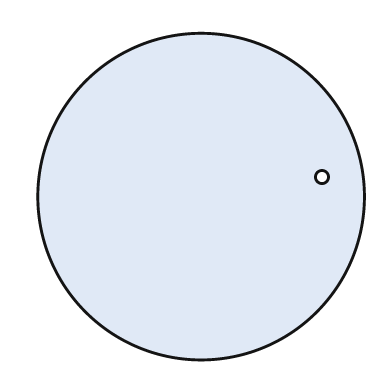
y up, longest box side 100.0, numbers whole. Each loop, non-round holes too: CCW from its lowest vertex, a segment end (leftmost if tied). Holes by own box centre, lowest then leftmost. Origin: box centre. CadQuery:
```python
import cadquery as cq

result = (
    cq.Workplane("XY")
    .moveTo(0.0, 0.0)
    .circle(50.0)
    .moveTo(37.0, 6.0)
    .circle(2.0)
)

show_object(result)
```